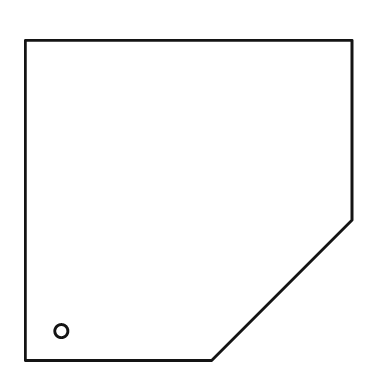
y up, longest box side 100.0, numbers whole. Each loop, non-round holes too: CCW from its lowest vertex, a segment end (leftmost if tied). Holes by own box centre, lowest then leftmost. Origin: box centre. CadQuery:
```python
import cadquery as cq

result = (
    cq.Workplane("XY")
    .moveTo(-50.0, -49.0)
    .lineTo(7.0, -49.0)
    .lineTo(50.0, -6.0)
    .lineTo(50.0, 49.0)
    .lineTo(-50.0, 49.0)
    .close()
    .moveTo(-39.0, -40.0)
    .circle(2.0)
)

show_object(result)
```